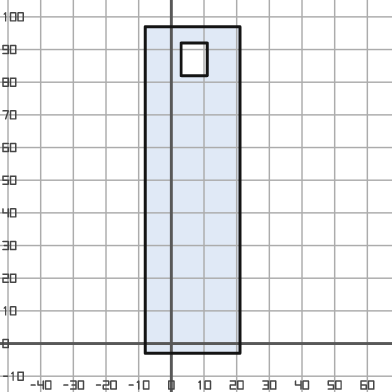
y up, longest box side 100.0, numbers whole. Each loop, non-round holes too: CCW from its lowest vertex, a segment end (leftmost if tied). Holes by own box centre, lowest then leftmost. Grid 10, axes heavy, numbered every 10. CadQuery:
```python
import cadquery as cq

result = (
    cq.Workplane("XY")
    .moveTo(-8.0, -3.0)
    .lineTo(21.0, -3.0)
    .lineTo(21.0, 97.0)
    .lineTo(-8.0, 97.0)
    .close()
    .moveTo(3.0, 82.0)
    .lineTo(11.0, 82.0)
    .lineTo(11.0, 92.0)
    .lineTo(3.0, 92.0)
    .close()
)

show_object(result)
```